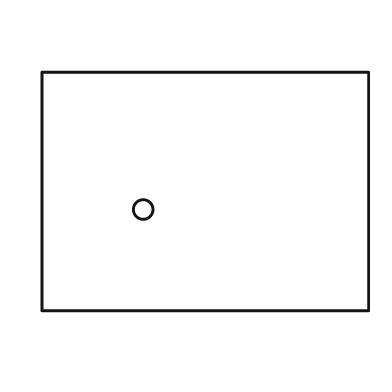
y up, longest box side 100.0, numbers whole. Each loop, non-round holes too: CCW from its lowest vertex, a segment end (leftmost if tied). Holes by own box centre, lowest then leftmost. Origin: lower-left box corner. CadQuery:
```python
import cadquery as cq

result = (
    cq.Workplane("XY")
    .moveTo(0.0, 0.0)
    .lineTo(100.0, 0.0)
    .lineTo(100.0, 73.0)
    .lineTo(0.0, 73.0)
    .close()
    .moveTo(31.0, 31.0)
    .circle(3.0)
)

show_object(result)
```